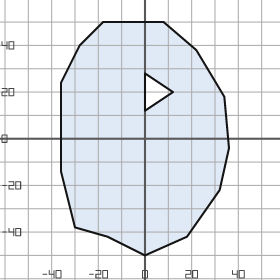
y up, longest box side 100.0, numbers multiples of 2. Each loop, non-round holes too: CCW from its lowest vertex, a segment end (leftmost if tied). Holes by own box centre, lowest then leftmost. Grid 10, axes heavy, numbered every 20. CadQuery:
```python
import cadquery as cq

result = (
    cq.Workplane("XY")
    .moveTo(0.0, -50.0)
    .lineTo(18.0, -42.0)
    .lineTo(32.0, -22.0)
    .lineTo(36.0, -4.0)
    .lineTo(34.0, 18.0)
    .lineTo(22.0, 38.0)
    .lineTo(8.0, 50.0)
    .lineTo(-18.0, 50.0)
    .lineTo(-28.0, 40.0)
    .lineTo(-36.0, 24.0)
    .lineTo(-36.0, -14.0)
    .lineTo(-30.0, -38.0)
    .lineTo(-16.0, -42.0)
    .close()
    .moveTo(0.0, 12.0)
    .lineTo(12.0, 20.0)
    .lineTo(0.0, 28.0)
    .close()
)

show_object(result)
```